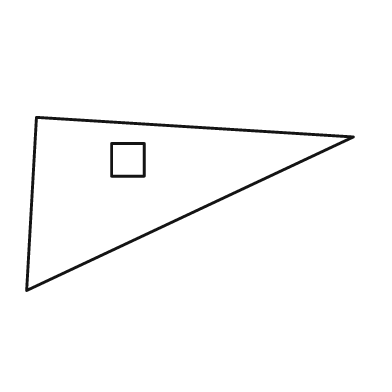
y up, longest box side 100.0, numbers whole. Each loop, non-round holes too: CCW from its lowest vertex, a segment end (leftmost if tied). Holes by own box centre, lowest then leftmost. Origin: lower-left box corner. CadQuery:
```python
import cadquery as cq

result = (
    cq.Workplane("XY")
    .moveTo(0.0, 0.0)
    .lineTo(100.0, 47.0)
    .lineTo(3.0, 53.0)
    .close()
    .moveTo(26.0, 35.0)
    .lineTo(36.0, 35.0)
    .lineTo(36.0, 45.0)
    .lineTo(26.0, 45.0)
    .close()
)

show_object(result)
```